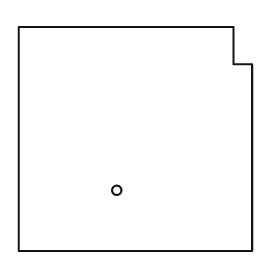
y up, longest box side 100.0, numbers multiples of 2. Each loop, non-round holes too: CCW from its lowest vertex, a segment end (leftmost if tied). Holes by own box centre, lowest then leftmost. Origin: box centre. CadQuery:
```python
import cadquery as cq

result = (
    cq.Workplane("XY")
    .moveTo(-50.0, -48.0)
    .lineTo(50.0, -48.0)
    .lineTo(50.0, 32.0)
    .lineTo(42.0, 32.0)
    .lineTo(42.0, 48.0)
    .lineTo(-50.0, 48.0)
    .close()
    .moveTo(-8.0, -22.0)
    .circle(2.0)
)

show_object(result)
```